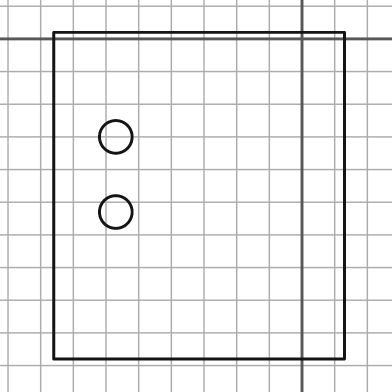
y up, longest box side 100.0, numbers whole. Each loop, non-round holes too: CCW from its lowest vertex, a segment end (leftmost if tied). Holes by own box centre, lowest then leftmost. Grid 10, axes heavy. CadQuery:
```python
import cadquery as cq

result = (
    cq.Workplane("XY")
    .moveTo(-76.0, -98.0)
    .lineTo(13.0, -98.0)
    .lineTo(13.0, 2.0)
    .lineTo(-76.0, 2.0)
    .close()
    .moveTo(-57.0, -53.0)
    .circle(5.0)
    .moveTo(-57.0, -30.0)
    .circle(5.0)
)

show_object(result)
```